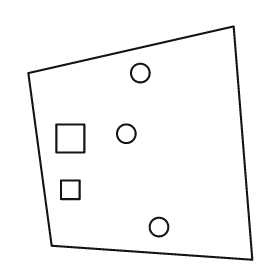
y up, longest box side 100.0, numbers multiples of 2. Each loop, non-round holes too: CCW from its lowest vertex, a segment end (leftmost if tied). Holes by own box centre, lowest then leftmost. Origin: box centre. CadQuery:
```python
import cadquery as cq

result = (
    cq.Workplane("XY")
    .moveTo(48.0, -50.0)
    .lineTo(40.0, 50.0)
    .lineTo(-48.0, 30.0)
    .lineTo(-38.0, -44.0)
    .close()
    .moveTo(8.0, -36.0)
    .circle(4.0)
    .moveTo(-34.0, -24.0)
    .lineTo(-26.0, -24.0)
    .lineTo(-26.0, -16.0)
    .lineTo(-34.0, -16.0)
    .close()
    .moveTo(-36.0, -4.0)
    .lineTo(-24.0, -4.0)
    .lineTo(-24.0, 8.0)
    .lineTo(-36.0, 8.0)
    .close()
    .moveTo(-6.0, 4.0)
    .circle(4.0)
    .moveTo(0.0, 30.0)
    .circle(4.0)
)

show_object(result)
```